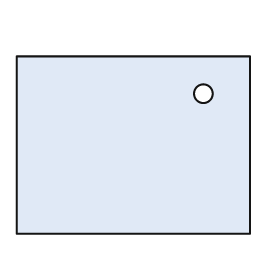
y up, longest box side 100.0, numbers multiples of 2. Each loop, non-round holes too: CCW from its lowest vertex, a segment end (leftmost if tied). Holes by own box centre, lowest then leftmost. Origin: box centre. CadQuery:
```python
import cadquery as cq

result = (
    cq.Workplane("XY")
    .moveTo(-50.0, -38.0)
    .lineTo(50.0, -38.0)
    .lineTo(50.0, 38.0)
    .lineTo(-50.0, 38.0)
    .close()
    .moveTo(30.0, 22.0)
    .circle(4.0)
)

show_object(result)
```